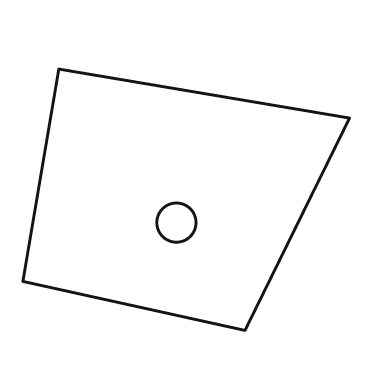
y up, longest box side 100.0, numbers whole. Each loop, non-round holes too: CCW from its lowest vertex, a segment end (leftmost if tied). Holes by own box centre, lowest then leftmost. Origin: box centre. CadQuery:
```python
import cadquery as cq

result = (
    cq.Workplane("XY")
    .moveTo(18.0, -40.0)
    .lineTo(50.0, 25.0)
    .lineTo(-39.0, 40.0)
    .lineTo(-50.0, -25.0)
    .close()
    .moveTo(-3.0, -7.0)
    .circle(6.0)
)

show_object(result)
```